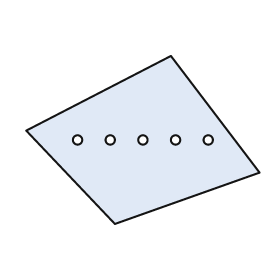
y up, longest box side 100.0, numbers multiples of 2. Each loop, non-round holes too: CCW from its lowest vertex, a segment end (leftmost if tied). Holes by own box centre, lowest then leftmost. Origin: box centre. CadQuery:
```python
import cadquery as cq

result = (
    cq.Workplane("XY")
    .moveTo(-12.0, -36.0)
    .lineTo(50.0, -14.0)
    .lineTo(12.0, 36.0)
    .lineTo(-50.0, 4.0)
    .close()
    .moveTo(-28.0, 0.0)
    .circle(2.0)
    .moveTo(-14.0, 0.0)
    .circle(2.0)
    .moveTo(0.0, 0.0)
    .circle(2.0)
    .moveTo(14.0, 0.0)
    .circle(2.0)
    .moveTo(28.0, 0.0)
    .circle(2.0)
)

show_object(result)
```